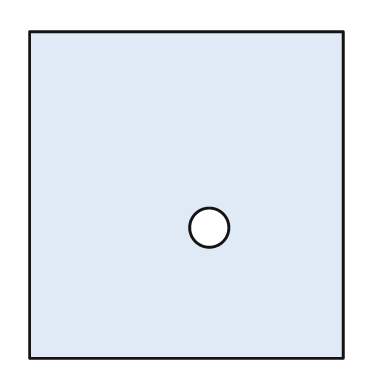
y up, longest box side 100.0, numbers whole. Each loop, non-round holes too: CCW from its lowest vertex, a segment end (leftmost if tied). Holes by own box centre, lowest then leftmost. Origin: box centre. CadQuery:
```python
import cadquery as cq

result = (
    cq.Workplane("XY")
    .moveTo(-48.0, -50.0)
    .lineTo(48.0, -50.0)
    .lineTo(48.0, 50.0)
    .lineTo(-48.0, 50.0)
    .close()
    .moveTo(7.0, -10.0)
    .circle(6.0)
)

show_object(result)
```